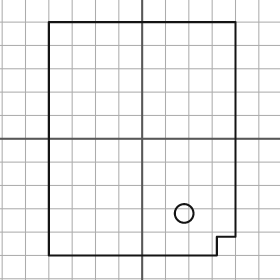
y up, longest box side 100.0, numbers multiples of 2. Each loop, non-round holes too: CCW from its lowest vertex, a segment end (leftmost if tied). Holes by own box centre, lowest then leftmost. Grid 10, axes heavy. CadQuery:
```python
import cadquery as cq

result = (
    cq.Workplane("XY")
    .moveTo(-40.0, -50.0)
    .lineTo(32.0, -50.0)
    .lineTo(32.0, -42.0)
    .lineTo(40.0, -42.0)
    .lineTo(40.0, 50.0)
    .lineTo(-40.0, 50.0)
    .close()
    .moveTo(18.0, -32.0)
    .circle(4.0)
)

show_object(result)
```